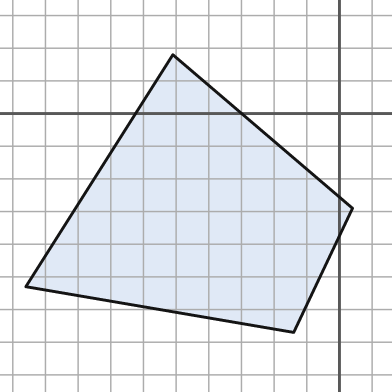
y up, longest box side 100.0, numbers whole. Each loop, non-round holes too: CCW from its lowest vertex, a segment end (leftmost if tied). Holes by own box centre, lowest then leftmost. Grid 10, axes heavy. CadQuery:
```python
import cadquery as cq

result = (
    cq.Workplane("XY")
    .moveTo(-14.0, -67.0)
    .lineTo(4.0, -29.0)
    .lineTo(-51.0, 18.0)
    .lineTo(-96.0, -53.0)
    .close()
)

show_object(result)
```